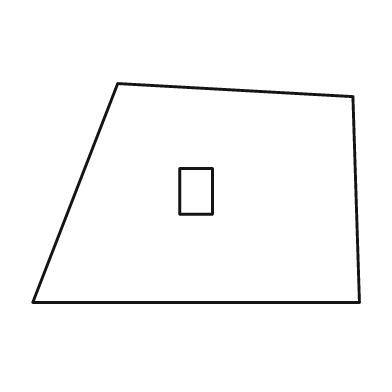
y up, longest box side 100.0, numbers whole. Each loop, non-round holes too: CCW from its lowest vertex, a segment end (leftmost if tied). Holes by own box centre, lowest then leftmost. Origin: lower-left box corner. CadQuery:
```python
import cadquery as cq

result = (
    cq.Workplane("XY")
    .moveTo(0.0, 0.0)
    .lineTo(100.0, 0.0)
    .lineTo(98.0, 63.0)
    .lineTo(26.0, 67.0)
    .close()
    .moveTo(45.0, 27.0)
    .lineTo(55.0, 27.0)
    .lineTo(55.0, 41.0)
    .lineTo(45.0, 41.0)
    .close()
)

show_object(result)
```